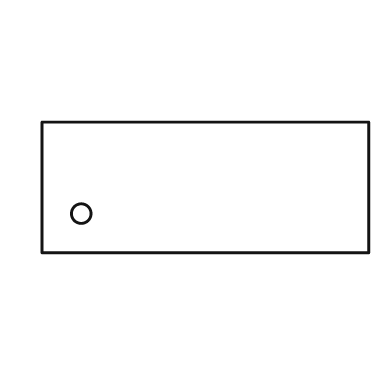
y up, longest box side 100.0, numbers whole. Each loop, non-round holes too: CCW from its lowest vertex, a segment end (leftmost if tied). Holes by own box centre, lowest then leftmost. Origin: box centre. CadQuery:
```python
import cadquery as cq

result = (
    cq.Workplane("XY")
    .moveTo(-50.0, -20.0)
    .lineTo(50.0, -20.0)
    .lineTo(50.0, 20.0)
    .lineTo(-50.0, 20.0)
    .close()
    .moveTo(-38.0, -8.0)
    .circle(3.0)
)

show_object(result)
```